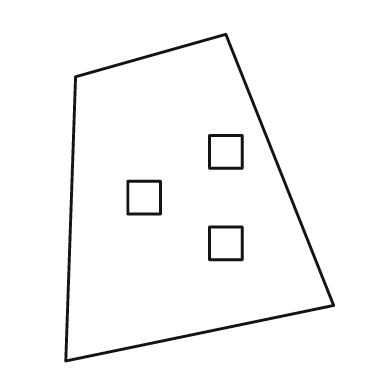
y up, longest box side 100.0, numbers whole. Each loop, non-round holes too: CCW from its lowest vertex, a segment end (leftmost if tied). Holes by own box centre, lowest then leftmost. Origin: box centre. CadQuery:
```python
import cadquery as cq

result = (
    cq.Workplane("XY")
    .moveTo(-41.0, -50.0)
    .lineTo(41.0, -33.0)
    .lineTo(8.0, 50.0)
    .lineTo(-38.0, 37.0)
    .close()
    .moveTo(3.0, -19.0)
    .lineTo(13.0, -19.0)
    .lineTo(13.0, -9.0)
    .lineTo(3.0, -9.0)
    .close()
    .moveTo(-22.0, -5.0)
    .lineTo(-12.0, -5.0)
    .lineTo(-12.0, 5.0)
    .lineTo(-22.0, 5.0)
    .close()
    .moveTo(3.0, 9.0)
    .lineTo(13.0, 9.0)
    .lineTo(13.0, 19.0)
    .lineTo(3.0, 19.0)
    .close()
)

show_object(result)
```